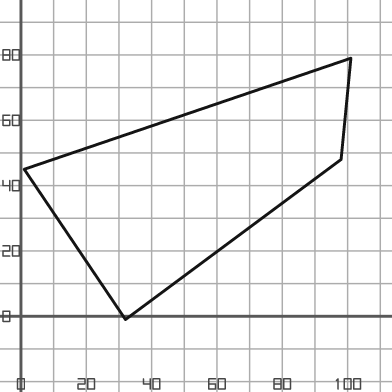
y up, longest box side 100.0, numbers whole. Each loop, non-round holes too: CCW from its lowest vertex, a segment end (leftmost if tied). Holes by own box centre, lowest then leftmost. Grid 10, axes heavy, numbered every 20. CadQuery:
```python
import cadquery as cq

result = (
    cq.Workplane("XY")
    .moveTo(32.0, -1.0)
    .lineTo(98.0, 48.0)
    .lineTo(101.0, 79.0)
    .lineTo(1.0, 45.0)
    .close()
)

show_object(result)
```